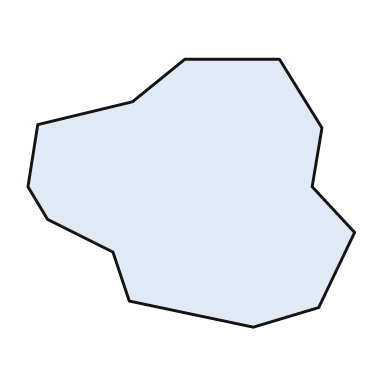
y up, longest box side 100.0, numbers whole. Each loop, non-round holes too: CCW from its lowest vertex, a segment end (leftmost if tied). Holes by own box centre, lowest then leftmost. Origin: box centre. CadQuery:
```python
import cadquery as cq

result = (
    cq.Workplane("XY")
    .moveTo(19.0, -41.0)
    .lineTo(39.0, -35.0)
    .lineTo(50.0, -12.0)
    .lineTo(37.0, 2.0)
    .lineTo(40.0, 20.0)
    .lineTo(27.0, 41.0)
    .lineTo(-2.0, 41.0)
    .lineTo(-18.0, 28.0)
    .lineTo(-47.0, 21.0)
    .lineTo(-50.0, 2.0)
    .lineTo(-44.0, -8.0)
    .lineTo(-24.0, -18.0)
    .lineTo(-19.0, -33.0)
    .close()
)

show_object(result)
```